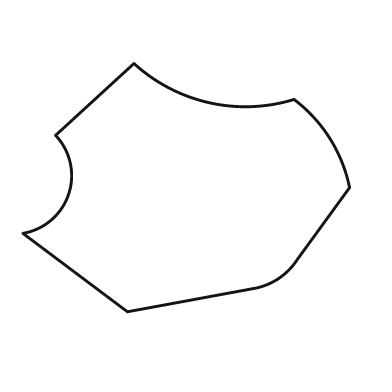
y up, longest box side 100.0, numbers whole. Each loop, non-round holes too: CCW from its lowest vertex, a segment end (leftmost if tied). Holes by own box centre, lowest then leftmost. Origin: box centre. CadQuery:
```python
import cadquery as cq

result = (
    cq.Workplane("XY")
    .moveTo(-18.0, -38.0)
    .lineTo(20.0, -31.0)
    .threePointArc((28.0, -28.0), (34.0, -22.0))
    .lineTo(50.0, 0.0)
    .threePointArc((44.0, 15.0), (33.0, 27.0))
    .threePointArc((7.0, 26.0), (-16.0, 38.0))
    .lineTo(-40.0, 16.0)
    .threePointArc((-36.0, -2.0), (-50.0, -14.0))
    .close()
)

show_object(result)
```